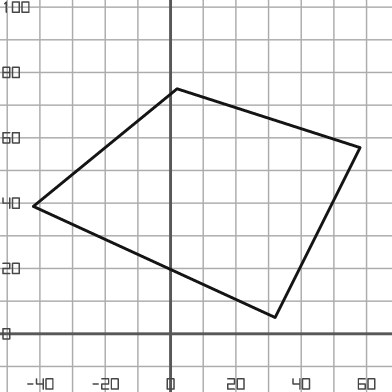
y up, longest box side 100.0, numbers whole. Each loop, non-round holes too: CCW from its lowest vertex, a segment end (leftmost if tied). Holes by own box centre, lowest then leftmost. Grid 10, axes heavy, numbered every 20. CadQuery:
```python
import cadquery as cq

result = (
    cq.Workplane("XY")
    .moveTo(32.0, 5.0)
    .lineTo(58.0, 57.0)
    .lineTo(2.0, 75.0)
    .lineTo(-42.0, 39.0)
    .close()
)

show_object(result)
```